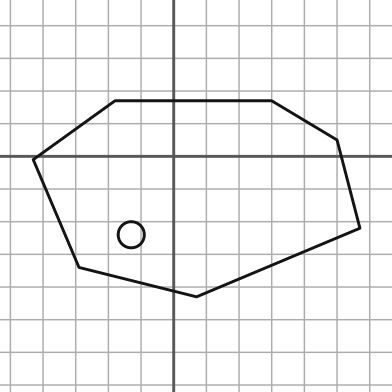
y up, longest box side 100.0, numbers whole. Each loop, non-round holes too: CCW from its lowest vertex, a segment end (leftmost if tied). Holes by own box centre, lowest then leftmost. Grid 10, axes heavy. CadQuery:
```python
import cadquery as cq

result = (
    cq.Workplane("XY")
    .moveTo(7.0, -43.0)
    .lineTo(57.0, -22.0)
    .lineTo(50.0, 5.0)
    .lineTo(30.0, 17.0)
    .lineTo(-18.0, 17.0)
    .lineTo(-43.0, -1.0)
    .lineTo(-29.0, -34.0)
    .close()
    .moveTo(-13.0, -24.0)
    .circle(4.0)
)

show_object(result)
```